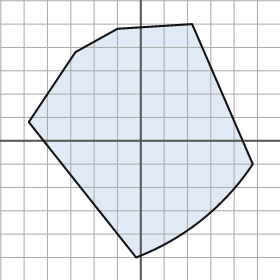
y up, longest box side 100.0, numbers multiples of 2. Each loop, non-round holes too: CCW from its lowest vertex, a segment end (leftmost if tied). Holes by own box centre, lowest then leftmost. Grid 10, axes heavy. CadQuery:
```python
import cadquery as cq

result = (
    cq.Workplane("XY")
    .moveTo(-2.0, -50.0)
    .threePointArc((26.0, -34.0), (48.0, -10.0))
    .lineTo(22.0, 50.0)
    .lineTo(-10.0, 48.0)
    .lineTo(-28.0, 38.0)
    .lineTo(-48.0, 8.0)
    .close()
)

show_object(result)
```